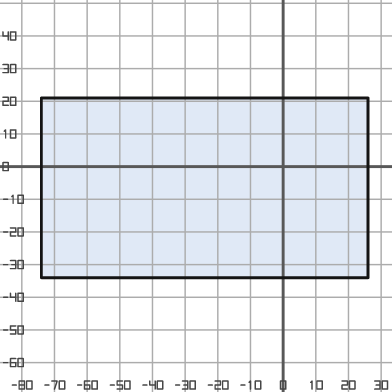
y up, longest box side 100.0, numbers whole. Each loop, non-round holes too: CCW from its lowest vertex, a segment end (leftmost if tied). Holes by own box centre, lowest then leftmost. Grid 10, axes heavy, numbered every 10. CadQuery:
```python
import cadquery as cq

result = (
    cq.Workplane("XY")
    .moveTo(-74.0, -34.0)
    .lineTo(26.0, -34.0)
    .lineTo(26.0, 21.0)
    .lineTo(-74.0, 21.0)
    .close()
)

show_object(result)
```